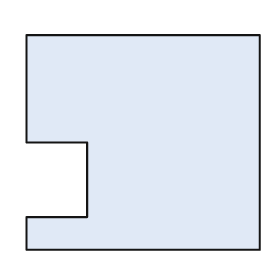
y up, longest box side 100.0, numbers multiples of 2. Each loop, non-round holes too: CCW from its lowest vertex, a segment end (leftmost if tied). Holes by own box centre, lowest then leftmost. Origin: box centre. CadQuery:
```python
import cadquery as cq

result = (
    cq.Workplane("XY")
    .moveTo(-50.0, -46.0)
    .lineTo(50.0, -46.0)
    .lineTo(50.0, 46.0)
    .lineTo(-50.0, 46.0)
    .lineTo(-50.0, 0.0)
    .lineTo(-24.0, 0.0)
    .lineTo(-24.0, -32.0)
    .lineTo(-50.0, -32.0)
    .close()
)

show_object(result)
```